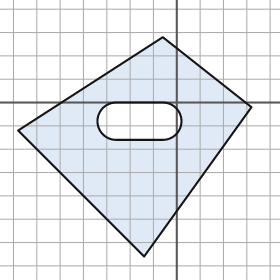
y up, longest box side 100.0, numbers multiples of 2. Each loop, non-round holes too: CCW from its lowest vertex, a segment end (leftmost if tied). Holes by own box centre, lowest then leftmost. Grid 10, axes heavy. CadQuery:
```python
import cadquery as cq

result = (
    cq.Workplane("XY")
    .moveTo(-14.0, -66.0)
    .lineTo(32.0, -2.0)
    .lineTo(-6.0, 28.0)
    .lineTo(-68.0, -12.0)
    .close()
    .moveTo(-26.0, -16.0)
    .lineTo(-6.0, -16.0)
    .threePointArc((2.0, -8.0), (-6.0, 0.0))
    .lineTo(-26.0, 0.0)
    .threePointArc((-34.0, -8.0), (-26.0, -16.0))
    .close()
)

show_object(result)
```